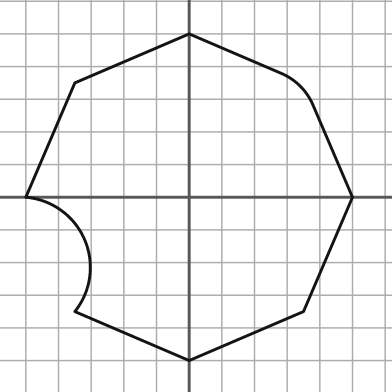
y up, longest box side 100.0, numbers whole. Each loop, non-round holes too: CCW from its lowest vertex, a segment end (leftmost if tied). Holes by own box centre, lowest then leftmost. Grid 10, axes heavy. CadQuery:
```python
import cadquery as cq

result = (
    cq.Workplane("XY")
    .moveTo(0.0, -50.0)
    .lineTo(35.0, -35.0)
    .lineTo(50.0, 0.0)
    .lineTo(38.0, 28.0)
    .threePointArc((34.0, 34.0), (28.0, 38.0))
    .lineTo(0.0, 50.0)
    .lineTo(-35.0, 35.0)
    .lineTo(-50.0, 0.0)
    .threePointArc((-32.0, -13.0), (-35.0, -35.0))
    .close()
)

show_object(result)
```